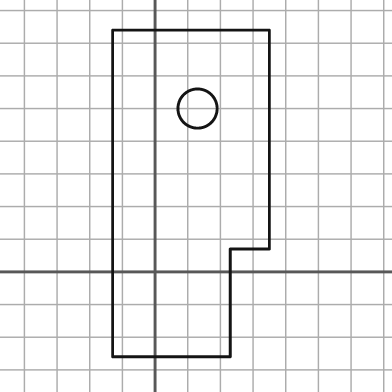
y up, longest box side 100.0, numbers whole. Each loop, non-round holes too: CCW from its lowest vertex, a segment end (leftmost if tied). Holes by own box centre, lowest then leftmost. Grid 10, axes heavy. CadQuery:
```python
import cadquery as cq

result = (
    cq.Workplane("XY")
    .moveTo(-13.0, -26.0)
    .lineTo(23.0, -26.0)
    .lineTo(23.0, 7.0)
    .lineTo(35.0, 7.0)
    .lineTo(35.0, 74.0)
    .lineTo(-13.0, 74.0)
    .close()
    .moveTo(13.0, 50.0)
    .circle(6.0)
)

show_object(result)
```